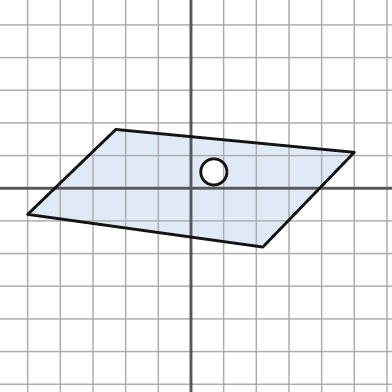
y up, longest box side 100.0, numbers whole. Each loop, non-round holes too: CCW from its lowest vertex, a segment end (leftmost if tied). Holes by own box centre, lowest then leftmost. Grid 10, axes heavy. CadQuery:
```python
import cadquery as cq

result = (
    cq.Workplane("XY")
    .moveTo(22.0, -18.0)
    .lineTo(50.0, 11.0)
    .lineTo(-23.0, 18.0)
    .lineTo(-50.0, -8.0)
    .close()
    .moveTo(7.0, 5.0)
    .circle(4.0)
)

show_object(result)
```